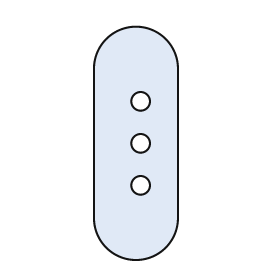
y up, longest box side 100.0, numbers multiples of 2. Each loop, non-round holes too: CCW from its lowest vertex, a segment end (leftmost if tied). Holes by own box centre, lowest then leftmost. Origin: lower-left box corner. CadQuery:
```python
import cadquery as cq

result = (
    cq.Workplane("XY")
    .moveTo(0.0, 18.0)
    .threePointArc((18.0, 0.0), (36.0, 18.0))
    .lineTo(36.0, 82.0)
    .threePointArc((18.0, 100.0), (0.0, 82.0))
    .close()
    .moveTo(20.0, 32.0)
    .circle(4.0)
    .moveTo(20.0, 50.0)
    .circle(4.0)
    .moveTo(20.0, 68.0)
    .circle(4.0)
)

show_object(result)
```